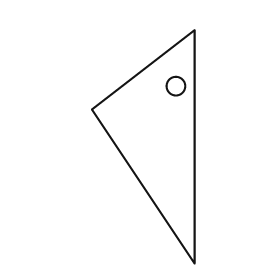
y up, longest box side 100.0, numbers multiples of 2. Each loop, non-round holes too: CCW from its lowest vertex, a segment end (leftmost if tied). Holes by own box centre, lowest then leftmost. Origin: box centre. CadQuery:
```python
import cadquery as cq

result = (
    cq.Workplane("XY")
    .moveTo(22.0, -50.0)
    .lineTo(22.0, 50.0)
    .lineTo(-22.0, 16.0)
    .close()
    .moveTo(14.0, 26.0)
    .circle(4.0)
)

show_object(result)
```